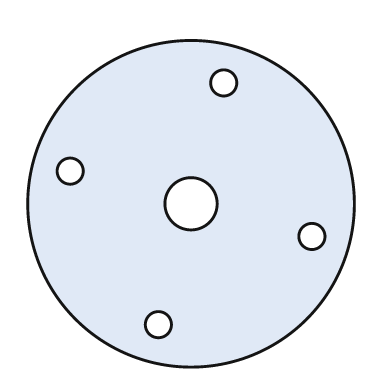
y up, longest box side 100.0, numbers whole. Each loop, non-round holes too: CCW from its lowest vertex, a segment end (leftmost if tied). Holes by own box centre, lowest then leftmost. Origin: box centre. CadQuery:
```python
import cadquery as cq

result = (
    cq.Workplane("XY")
    .moveTo(0.0, 0.0)
    .circle(50.0)
    .moveTo(-10.0, -37.0)
    .circle(4.0)
    .moveTo(37.0, -10.0)
    .circle(4.0)
    .moveTo(0.0, 0.0)
    .circle(8.0)
    .moveTo(-37.0, 10.0)
    .circle(4.0)
    .moveTo(10.0, 37.0)
    .circle(4.0)
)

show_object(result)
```